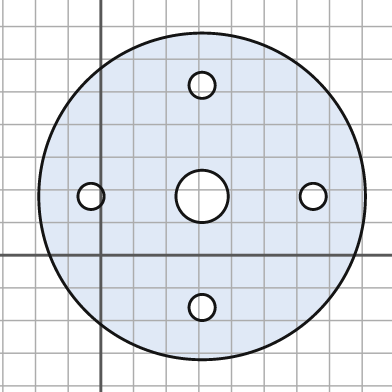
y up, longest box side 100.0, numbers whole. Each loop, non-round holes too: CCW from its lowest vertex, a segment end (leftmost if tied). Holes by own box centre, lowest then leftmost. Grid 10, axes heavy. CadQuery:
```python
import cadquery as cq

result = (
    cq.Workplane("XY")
    .moveTo(31.0, 18.0)
    .circle(50.0)
    .moveTo(31.0, -16.0)
    .circle(4.0)
    .moveTo(-3.0, 18.0)
    .circle(4.0)
    .moveTo(31.0, 18.0)
    .circle(8.0)
    .moveTo(65.0, 18.0)
    .circle(4.0)
    .moveTo(31.0, 52.0)
    .circle(4.0)
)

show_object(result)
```